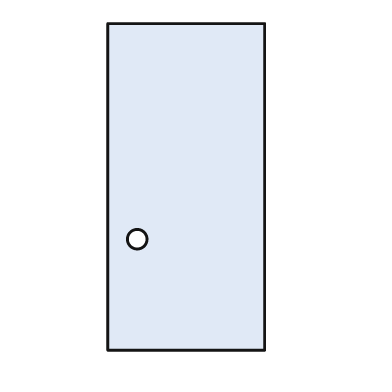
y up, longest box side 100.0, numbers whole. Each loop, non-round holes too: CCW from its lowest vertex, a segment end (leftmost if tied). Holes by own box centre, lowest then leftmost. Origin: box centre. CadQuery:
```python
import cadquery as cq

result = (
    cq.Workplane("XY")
    .moveTo(-24.0, -50.0)
    .lineTo(24.0, -50.0)
    .lineTo(24.0, 50.0)
    .lineTo(-24.0, 50.0)
    .close()
    .moveTo(-15.0, -16.0)
    .circle(3.0)
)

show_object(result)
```